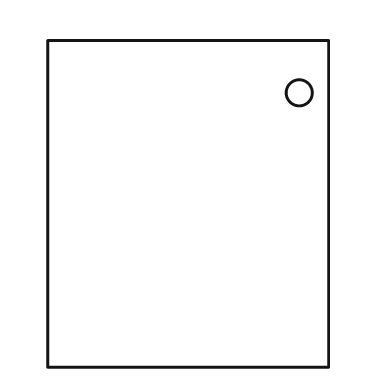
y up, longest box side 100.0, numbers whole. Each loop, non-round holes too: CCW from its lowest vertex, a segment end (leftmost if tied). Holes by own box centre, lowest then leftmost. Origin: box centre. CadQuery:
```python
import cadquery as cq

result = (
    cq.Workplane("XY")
    .moveTo(-43.0, -50.0)
    .lineTo(43.0, -50.0)
    .lineTo(43.0, 50.0)
    .lineTo(-43.0, 50.0)
    .close()
    .moveTo(34.0, 34.0)
    .circle(4.0)
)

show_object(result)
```